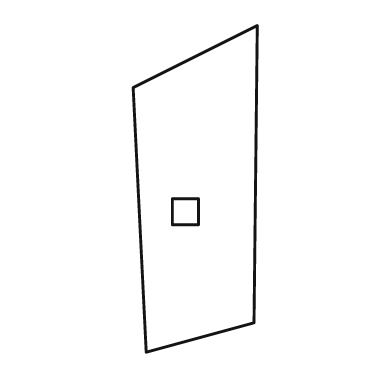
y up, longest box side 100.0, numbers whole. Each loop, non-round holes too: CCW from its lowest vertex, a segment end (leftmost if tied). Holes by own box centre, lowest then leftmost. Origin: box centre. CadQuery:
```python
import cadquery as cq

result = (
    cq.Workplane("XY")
    .moveTo(-15.0, -50.0)
    .lineTo(18.0, -41.0)
    .lineTo(19.0, 50.0)
    .lineTo(-19.0, 31.0)
    .close()
    .moveTo(-7.0, -11.0)
    .lineTo(1.0, -11.0)
    .lineTo(1.0, -3.0)
    .lineTo(-7.0, -3.0)
    .close()
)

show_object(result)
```